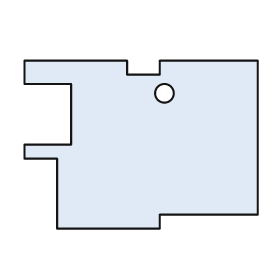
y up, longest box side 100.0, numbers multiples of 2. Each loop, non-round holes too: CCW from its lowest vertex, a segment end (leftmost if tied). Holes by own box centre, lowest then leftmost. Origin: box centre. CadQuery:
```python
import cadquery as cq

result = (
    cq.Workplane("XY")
    .moveTo(-36.0, -36.0)
    .lineTo(8.0, -36.0)
    .lineTo(8.0, -30.0)
    .lineTo(50.0, -30.0)
    .lineTo(50.0, 36.0)
    .lineTo(8.0, 36.0)
    .lineTo(8.0, 30.0)
    .lineTo(-6.0, 30.0)
    .lineTo(-6.0, 36.0)
    .lineTo(-50.0, 36.0)
    .lineTo(-50.0, 26.0)
    .lineTo(-30.0, 26.0)
    .lineTo(-30.0, 0.0)
    .lineTo(-50.0, 0.0)
    .lineTo(-50.0, -6.0)
    .lineTo(-36.0, -6.0)
    .close()
    .moveTo(10.0, 22.0)
    .circle(4.0)
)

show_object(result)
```